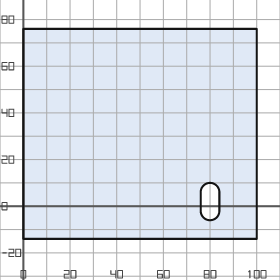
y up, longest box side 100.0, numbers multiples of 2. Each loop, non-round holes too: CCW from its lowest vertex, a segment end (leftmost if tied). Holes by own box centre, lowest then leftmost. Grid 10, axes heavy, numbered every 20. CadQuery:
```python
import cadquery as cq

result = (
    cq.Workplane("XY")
    .moveTo(0.0, -14.0)
    .lineTo(100.0, -14.0)
    .lineTo(100.0, 76.0)
    .lineTo(0.0, 76.0)
    .close()
    .moveTo(76.0, -2.0)
    .threePointArc((80.0, -6.0), (84.0, -2.0))
    .lineTo(84.0, 6.0)
    .threePointArc((80.0, 10.0), (76.0, 6.0))
    .close()
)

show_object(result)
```